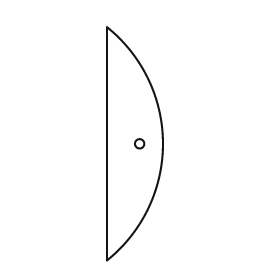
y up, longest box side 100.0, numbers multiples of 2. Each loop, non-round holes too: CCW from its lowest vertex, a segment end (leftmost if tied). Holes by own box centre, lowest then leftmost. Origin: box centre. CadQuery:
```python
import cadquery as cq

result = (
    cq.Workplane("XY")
    .moveTo(-12.0, -50.0)
    .threePointArc((12.0, 0.0), (-12.0, 50.0))
    .close()
    .moveTo(2.0, 0.0)
    .circle(2.0)
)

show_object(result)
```